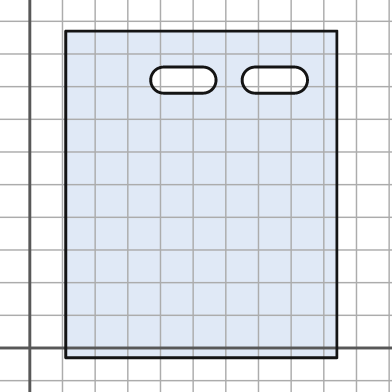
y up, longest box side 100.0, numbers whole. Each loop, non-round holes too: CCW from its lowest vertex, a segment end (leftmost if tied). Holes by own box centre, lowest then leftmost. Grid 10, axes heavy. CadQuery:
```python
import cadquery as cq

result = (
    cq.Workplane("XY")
    .moveTo(11.0, -3.0)
    .lineTo(94.0, -3.0)
    .lineTo(94.0, 97.0)
    .lineTo(11.0, 97.0)
    .close()
    .moveTo(41.0, 78.0)
    .lineTo(53.0, 78.0)
    .threePointArc((57.0, 82.0), (53.0, 86.0))
    .lineTo(41.0, 86.0)
    .threePointArc((37.0, 82.0), (41.0, 78.0))
    .close()
    .moveTo(69.0, 78.0)
    .lineTo(81.0, 78.0)
    .threePointArc((85.0, 82.0), (81.0, 86.0))
    .lineTo(69.0, 86.0)
    .threePointArc((65.0, 82.0), (69.0, 78.0))
    .close()
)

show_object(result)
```